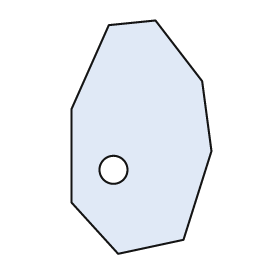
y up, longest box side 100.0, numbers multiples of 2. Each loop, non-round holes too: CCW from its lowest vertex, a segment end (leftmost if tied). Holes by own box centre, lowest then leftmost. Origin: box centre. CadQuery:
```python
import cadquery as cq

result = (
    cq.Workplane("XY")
    .moveTo(-10.0, -50.0)
    .lineTo(18.0, -44.0)
    .lineTo(30.0, -6.0)
    .lineTo(26.0, 24.0)
    .lineTo(6.0, 50.0)
    .lineTo(-14.0, 48.0)
    .lineTo(-30.0, 12.0)
    .lineTo(-30.0, -28.0)
    .close()
    .moveTo(-12.0, -14.0)
    .circle(6.0)
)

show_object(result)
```